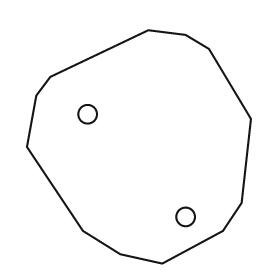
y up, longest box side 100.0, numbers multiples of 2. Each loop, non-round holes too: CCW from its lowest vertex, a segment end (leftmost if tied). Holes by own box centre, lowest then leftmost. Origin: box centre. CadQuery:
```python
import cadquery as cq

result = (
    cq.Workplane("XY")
    .moveTo(10.0, -50.0)
    .lineTo(36.0, -36.0)
    .lineTo(44.0, -24.0)
    .lineTo(48.0, 12.0)
    .lineTo(30.0, 42.0)
    .lineTo(20.0, 48.0)
    .lineTo(4.0, 50.0)
    .lineTo(-38.0, 30.0)
    .lineTo(-44.0, 22.0)
    .lineTo(-48.0, 0.0)
    .lineTo(-24.0, -36.0)
    .lineTo(-8.0, -46.0)
    .close()
    .moveTo(20.0, -30.0)
    .circle(4.0)
    .moveTo(-22.0, 14.0)
    .circle(4.0)
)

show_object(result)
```